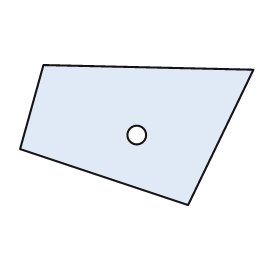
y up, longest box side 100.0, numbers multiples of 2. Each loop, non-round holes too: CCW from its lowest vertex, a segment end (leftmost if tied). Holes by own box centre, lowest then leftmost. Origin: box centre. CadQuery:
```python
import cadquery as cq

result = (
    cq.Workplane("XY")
    .moveTo(22.0, -30.0)
    .lineTo(50.0, 28.0)
    .lineTo(-40.0, 30.0)
    .lineTo(-50.0, -6.0)
    .close()
    .moveTo(0.0, 0.0)
    .circle(4.0)
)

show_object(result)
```